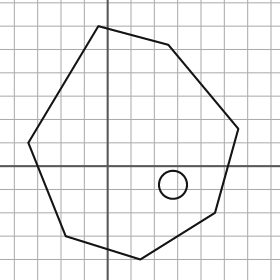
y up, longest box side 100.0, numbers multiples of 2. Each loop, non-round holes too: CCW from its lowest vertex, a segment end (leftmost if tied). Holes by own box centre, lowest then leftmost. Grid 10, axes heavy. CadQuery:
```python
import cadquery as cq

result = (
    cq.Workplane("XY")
    .moveTo(14.0, -40.0)
    .lineTo(46.0, -20.0)
    .lineTo(56.0, 16.0)
    .lineTo(26.0, 52.0)
    .lineTo(-4.0, 60.0)
    .lineTo(-34.0, 10.0)
    .lineTo(-18.0, -30.0)
    .close()
    .moveTo(28.0, -8.0)
    .circle(6.0)
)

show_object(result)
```